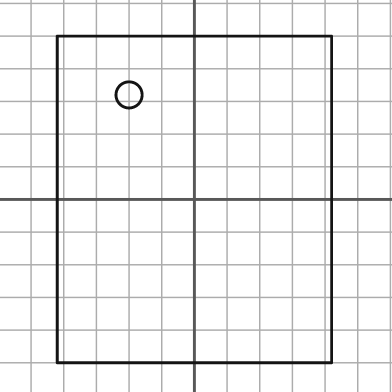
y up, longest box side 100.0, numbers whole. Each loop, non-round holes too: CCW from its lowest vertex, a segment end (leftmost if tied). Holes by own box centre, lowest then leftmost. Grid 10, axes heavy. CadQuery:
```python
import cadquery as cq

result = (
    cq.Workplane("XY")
    .moveTo(-42.0, -50.0)
    .lineTo(42.0, -50.0)
    .lineTo(42.0, 50.0)
    .lineTo(-42.0, 50.0)
    .close()
    .moveTo(-20.0, 32.0)
    .circle(4.0)
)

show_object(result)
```